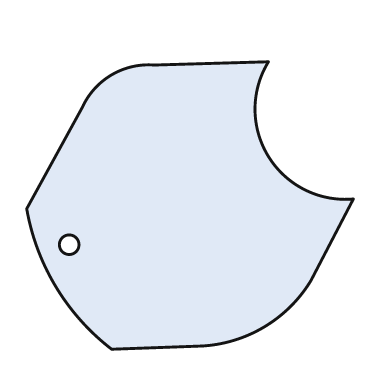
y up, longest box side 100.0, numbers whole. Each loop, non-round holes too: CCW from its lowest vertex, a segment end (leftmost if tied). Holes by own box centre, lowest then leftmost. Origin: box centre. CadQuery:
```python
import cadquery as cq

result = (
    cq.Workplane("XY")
    .moveTo(-24.0, -44.0)
    .lineTo(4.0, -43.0)
    .threePointArc((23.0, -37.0), (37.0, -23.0))
    .lineTo(50.0, 2.0)
    .threePointArc((24.0, 15.0), (24.0, 44.0))
    .lineTo(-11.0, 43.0)
    .threePointArc((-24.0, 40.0), (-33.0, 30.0))
    .lineTo(-50.0, -1.0)
    .threePointArc((-41.0, -25.0), (-24.0, -44.0))
    .close()
    .moveTo(-37.0, -12.0)
    .circle(3.0)
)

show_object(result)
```